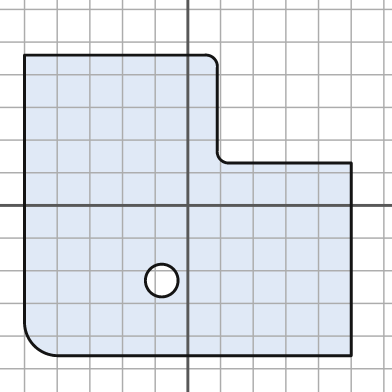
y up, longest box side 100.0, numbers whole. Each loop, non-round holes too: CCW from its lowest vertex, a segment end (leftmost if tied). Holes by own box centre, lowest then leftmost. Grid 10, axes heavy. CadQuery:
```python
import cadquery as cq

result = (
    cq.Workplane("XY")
    .moveTo(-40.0, -46.0)
    .lineTo(50.0, -46.0)
    .lineTo(50.0, 13.0)
    .lineTo(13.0, 13.0)
    .threePointArc((10.0, 14.0), (9.0, 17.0))
    .lineTo(9.0, 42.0)
    .threePointArc((8.0, 45.0), (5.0, 46.0))
    .lineTo(-50.0, 46.0)
    .lineTo(-50.0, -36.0)
    .threePointArc((-47.0, -43.0), (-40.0, -46.0))
    .close()
    .moveTo(-8.0, -23.0)
    .circle(5.0)
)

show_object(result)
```